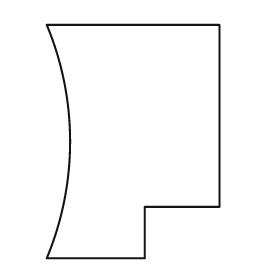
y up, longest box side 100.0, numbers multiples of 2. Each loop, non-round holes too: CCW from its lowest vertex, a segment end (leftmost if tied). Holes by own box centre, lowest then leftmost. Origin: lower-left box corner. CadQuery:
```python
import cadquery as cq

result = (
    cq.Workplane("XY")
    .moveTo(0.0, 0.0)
    .lineTo(42.0, 0.0)
    .lineTo(42.0, 22.0)
    .lineTo(74.0, 22.0)
    .lineTo(74.0, 100.0)
    .lineTo(0.0, 100.0)
    .threePointArc((10.0, 50.0), (0.0, 0.0))
    .close()
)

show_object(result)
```